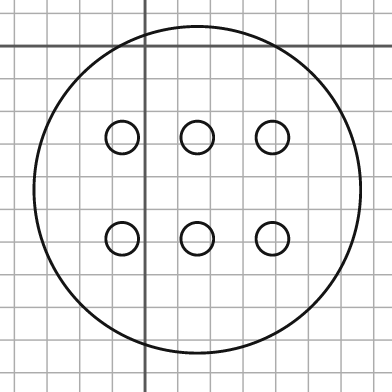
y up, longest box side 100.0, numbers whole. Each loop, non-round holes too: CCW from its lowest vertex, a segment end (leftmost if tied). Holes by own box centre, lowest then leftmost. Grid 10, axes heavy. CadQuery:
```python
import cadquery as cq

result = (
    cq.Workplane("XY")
    .moveTo(16.0, -44.0)
    .circle(50.0)
    .moveTo(-7.0, -59.0)
    .circle(5.0)
    .moveTo(16.0, -59.0)
    .circle(5.0)
    .moveTo(39.0, -59.0)
    .circle(5.0)
    .moveTo(-7.0, -28.0)
    .circle(5.0)
    .moveTo(16.0, -28.0)
    .circle(5.0)
    .moveTo(39.0, -28.0)
    .circle(5.0)
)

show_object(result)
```